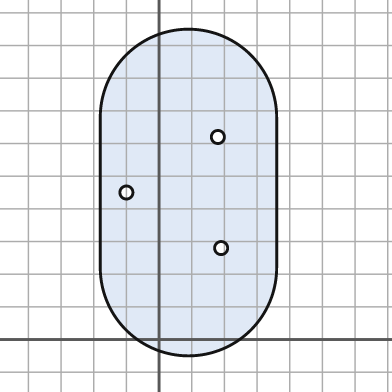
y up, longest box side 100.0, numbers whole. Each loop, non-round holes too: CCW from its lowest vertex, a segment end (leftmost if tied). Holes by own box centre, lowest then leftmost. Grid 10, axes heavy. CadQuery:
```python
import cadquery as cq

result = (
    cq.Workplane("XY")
    .moveTo(-18.0, 22.0)
    .threePointArc((9.0, -5.0), (36.0, 22.0))
    .lineTo(36.0, 68.0)
    .threePointArc((9.0, 95.0), (-18.0, 68.0))
    .close()
    .moveTo(19.0, 28.0)
    .circle(2.0)
    .moveTo(-10.0, 45.0)
    .circle(2.0)
    .moveTo(18.0, 62.0)
    .circle(2.0)
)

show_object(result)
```